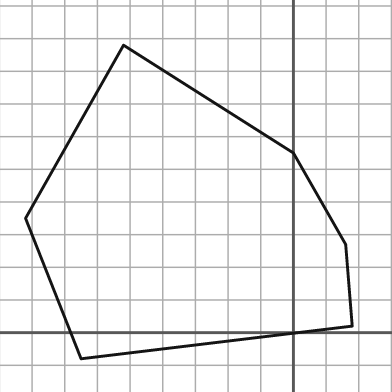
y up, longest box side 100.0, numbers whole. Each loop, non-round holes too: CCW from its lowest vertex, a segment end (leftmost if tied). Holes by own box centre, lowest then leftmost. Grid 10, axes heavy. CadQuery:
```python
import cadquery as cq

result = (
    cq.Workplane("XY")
    .moveTo(-65.0, -8.0)
    .lineTo(18.0, 2.0)
    .lineTo(16.0, 27.0)
    .lineTo(0.0, 55.0)
    .lineTo(-52.0, 88.0)
    .lineTo(-82.0, 35.0)
    .close()
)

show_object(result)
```